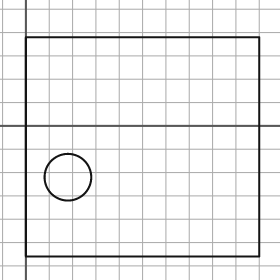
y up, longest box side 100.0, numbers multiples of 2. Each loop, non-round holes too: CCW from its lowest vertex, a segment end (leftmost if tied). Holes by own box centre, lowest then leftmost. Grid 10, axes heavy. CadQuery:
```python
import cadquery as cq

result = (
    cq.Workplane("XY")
    .moveTo(0.0, -56.0)
    .lineTo(100.0, -56.0)
    .lineTo(100.0, 38.0)
    .lineTo(0.0, 38.0)
    .close()
    .moveTo(18.0, -22.0)
    .circle(10.0)
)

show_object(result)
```